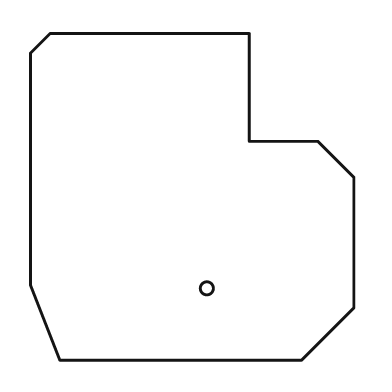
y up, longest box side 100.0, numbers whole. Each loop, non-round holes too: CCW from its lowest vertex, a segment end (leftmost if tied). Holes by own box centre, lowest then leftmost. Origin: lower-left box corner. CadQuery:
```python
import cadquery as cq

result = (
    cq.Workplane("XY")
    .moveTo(9.0, 0.0)
    .lineTo(83.0, 0.0)
    .lineTo(99.0, 16.0)
    .lineTo(99.0, 56.0)
    .lineTo(88.0, 67.0)
    .lineTo(67.0, 67.0)
    .lineTo(67.0, 100.0)
    .lineTo(6.0, 100.0)
    .lineTo(0.0, 94.0)
    .lineTo(0.0, 23.0)
    .close()
    .moveTo(54.0, 22.0)
    .circle(2.0)
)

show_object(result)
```